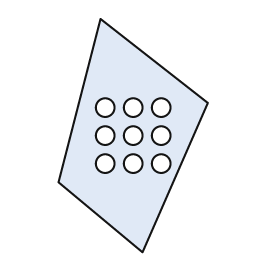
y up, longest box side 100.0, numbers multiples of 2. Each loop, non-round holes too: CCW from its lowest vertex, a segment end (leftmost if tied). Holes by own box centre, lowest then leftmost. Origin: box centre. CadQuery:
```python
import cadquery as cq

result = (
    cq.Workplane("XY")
    .moveTo(4.0, -50.0)
    .lineTo(32.0, 14.0)
    .lineTo(-14.0, 50.0)
    .lineTo(-32.0, -20.0)
    .close()
    .moveTo(-12.0, -12.0)
    .circle(4.0)
    .moveTo(0.0, -12.0)
    .circle(4.0)
    .moveTo(12.0, -12.0)
    .circle(4.0)
    .moveTo(-12.0, 0.0)
    .circle(4.0)
    .moveTo(0.0, 0.0)
    .circle(4.0)
    .moveTo(12.0, 0.0)
    .circle(4.0)
    .moveTo(-12.0, 12.0)
    .circle(4.0)
    .moveTo(0.0, 12.0)
    .circle(4.0)
    .moveTo(12.0, 12.0)
    .circle(4.0)
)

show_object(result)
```